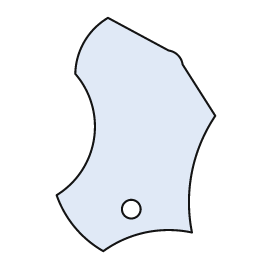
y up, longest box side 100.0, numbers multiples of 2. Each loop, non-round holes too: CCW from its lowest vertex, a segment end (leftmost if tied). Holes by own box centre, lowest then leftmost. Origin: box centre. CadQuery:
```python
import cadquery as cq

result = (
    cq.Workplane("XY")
    .moveTo(-14.0, -50.0)
    .threePointArc((4.0, -42.0), (24.0, -42.0))
    .threePointArc((24.0, -16.0), (34.0, 8.0))
    .lineTo(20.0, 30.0)
    .threePointArc((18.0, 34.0), (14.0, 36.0))
    .lineTo(-12.0, 50.0)
    .threePointArc((-22.0, 40.0), (-26.0, 26.0))
    .threePointArc((-18.0, -2.0), (-34.0, -26.0))
    .threePointArc((-26.0, -40.0), (-14.0, -50.0))
    .close()
    .moveTo(-2.0, -32.0)
    .circle(4.0)
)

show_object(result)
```